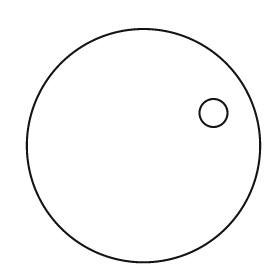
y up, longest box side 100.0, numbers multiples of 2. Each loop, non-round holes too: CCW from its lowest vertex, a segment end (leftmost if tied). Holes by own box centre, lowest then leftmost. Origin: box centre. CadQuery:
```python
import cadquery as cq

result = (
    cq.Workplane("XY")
    .moveTo(0.0, 0.0)
    .circle(50.0)
    .moveTo(30.0, 14.0)
    .circle(6.0)
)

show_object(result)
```